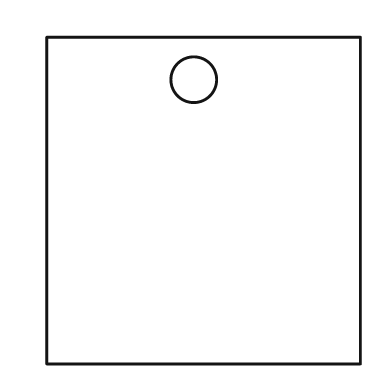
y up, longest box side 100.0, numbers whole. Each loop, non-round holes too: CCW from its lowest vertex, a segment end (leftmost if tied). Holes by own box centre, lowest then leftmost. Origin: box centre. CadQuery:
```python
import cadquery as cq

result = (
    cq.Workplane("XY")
    .moveTo(-48.0, -50.0)
    .lineTo(48.0, -50.0)
    .lineTo(48.0, 50.0)
    .lineTo(-48.0, 50.0)
    .close()
    .moveTo(-3.0, 37.0)
    .circle(7.0)
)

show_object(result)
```